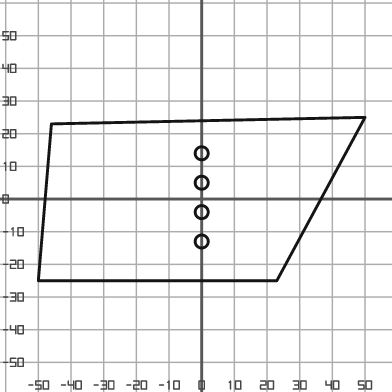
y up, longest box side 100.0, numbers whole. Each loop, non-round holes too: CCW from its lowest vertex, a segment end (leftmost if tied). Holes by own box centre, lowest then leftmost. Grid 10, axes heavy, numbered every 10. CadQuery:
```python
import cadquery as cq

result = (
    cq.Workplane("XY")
    .moveTo(-50.0, -25.0)
    .lineTo(23.0, -25.0)
    .lineTo(50.0, 25.0)
    .lineTo(-46.0, 23.0)
    .close()
    .moveTo(0.0, -13.0)
    .circle(2.0)
    .moveTo(0.0, -4.0)
    .circle(2.0)
    .moveTo(0.0, 5.0)
    .circle(2.0)
    .moveTo(0.0, 14.0)
    .circle(2.0)
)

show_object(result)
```